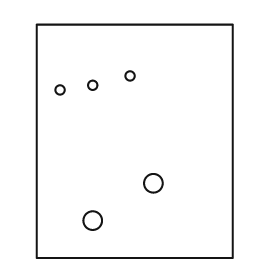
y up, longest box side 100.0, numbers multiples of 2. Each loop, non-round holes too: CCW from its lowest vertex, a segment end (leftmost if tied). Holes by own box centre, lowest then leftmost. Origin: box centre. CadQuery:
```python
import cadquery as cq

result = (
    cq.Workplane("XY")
    .moveTo(-42.0, -50.0)
    .lineTo(42.0, -50.0)
    .lineTo(42.0, 50.0)
    .lineTo(-42.0, 50.0)
    .close()
    .moveTo(-18.0, -34.0)
    .circle(4.0)
    .moveTo(8.0, -18.0)
    .circle(4.0)
    .moveTo(-32.0, 22.0)
    .circle(2.0)
    .moveTo(-18.0, 24.0)
    .circle(2.0)
    .moveTo(-2.0, 28.0)
    .circle(2.0)
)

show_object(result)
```